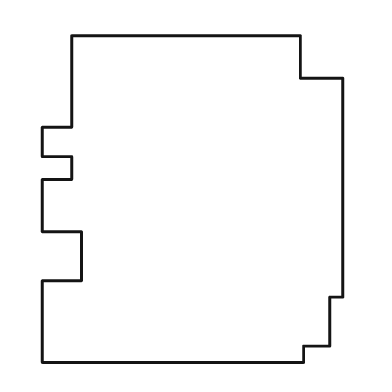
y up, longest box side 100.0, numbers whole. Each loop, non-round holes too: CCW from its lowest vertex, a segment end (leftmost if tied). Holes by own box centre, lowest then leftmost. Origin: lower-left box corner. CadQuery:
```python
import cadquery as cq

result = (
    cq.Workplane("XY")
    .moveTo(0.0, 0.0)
    .lineTo(80.0, 0.0)
    .lineTo(80.0, 5.0)
    .lineTo(88.0, 5.0)
    .lineTo(88.0, 20.0)
    .lineTo(92.0, 20.0)
    .lineTo(92.0, 87.0)
    .lineTo(79.0, 87.0)
    .lineTo(79.0, 100.0)
    .lineTo(9.0, 100.0)
    .lineTo(9.0, 72.0)
    .lineTo(0.0, 72.0)
    .lineTo(0.0, 63.0)
    .lineTo(9.0, 63.0)
    .lineTo(9.0, 56.0)
    .lineTo(0.0, 56.0)
    .lineTo(0.0, 40.0)
    .lineTo(12.0, 40.0)
    .lineTo(12.0, 25.0)
    .lineTo(0.0, 25.0)
    .close()
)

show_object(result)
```